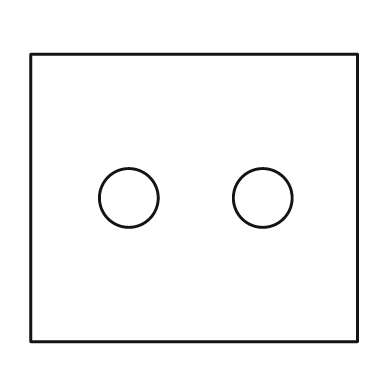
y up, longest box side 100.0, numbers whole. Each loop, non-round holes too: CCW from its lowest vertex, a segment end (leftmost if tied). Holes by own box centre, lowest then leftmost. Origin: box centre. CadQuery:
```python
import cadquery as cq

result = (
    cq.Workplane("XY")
    .moveTo(-50.0, -44.0)
    .lineTo(50.0, -44.0)
    .lineTo(50.0, 44.0)
    .lineTo(-50.0, 44.0)
    .close()
    .moveTo(-20.0, 0.0)
    .circle(9.0)
    .moveTo(21.0, 0.0)
    .circle(9.0)
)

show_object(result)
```